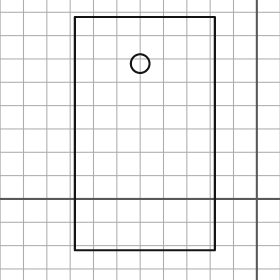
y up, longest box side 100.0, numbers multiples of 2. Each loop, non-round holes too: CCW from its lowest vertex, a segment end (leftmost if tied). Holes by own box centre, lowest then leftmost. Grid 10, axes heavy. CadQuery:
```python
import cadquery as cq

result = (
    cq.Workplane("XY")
    .moveTo(-78.0, -22.0)
    .lineTo(-18.0, -22.0)
    .lineTo(-18.0, 78.0)
    .lineTo(-78.0, 78.0)
    .close()
    .moveTo(-50.0, 58.0)
    .circle(4.0)
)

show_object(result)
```